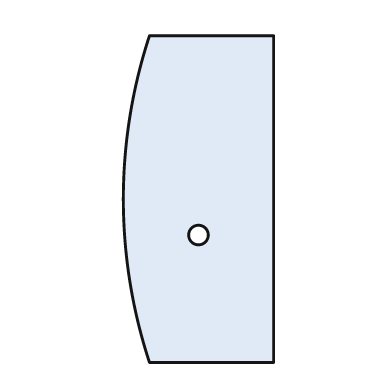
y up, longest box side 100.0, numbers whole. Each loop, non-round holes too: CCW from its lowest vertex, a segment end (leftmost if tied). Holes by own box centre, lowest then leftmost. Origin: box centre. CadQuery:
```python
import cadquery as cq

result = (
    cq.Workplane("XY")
    .moveTo(-15.0, -50.0)
    .lineTo(23.0, -50.0)
    .lineTo(23.0, 50.0)
    .lineTo(-15.0, 50.0)
    .threePointArc((-23.0, 0.0), (-15.0, -50.0))
    .close()
    .moveTo(0.0, -11.0)
    .circle(3.0)
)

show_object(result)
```